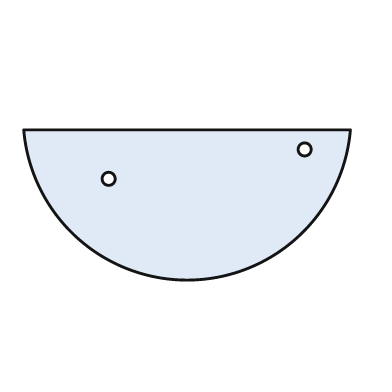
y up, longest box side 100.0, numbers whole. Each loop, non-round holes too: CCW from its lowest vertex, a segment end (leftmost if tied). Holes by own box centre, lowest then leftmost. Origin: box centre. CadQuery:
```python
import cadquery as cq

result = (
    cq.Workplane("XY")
    .moveTo(-50.0, 23.0)
    .threePointArc((0.0, -23.0), (50.0, 23.0))
    .close()
    .moveTo(-24.0, 8.0)
    .circle(2.0)
    .moveTo(36.0, 17.0)
    .circle(2.0)
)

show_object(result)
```